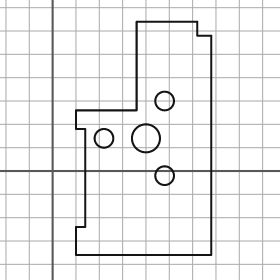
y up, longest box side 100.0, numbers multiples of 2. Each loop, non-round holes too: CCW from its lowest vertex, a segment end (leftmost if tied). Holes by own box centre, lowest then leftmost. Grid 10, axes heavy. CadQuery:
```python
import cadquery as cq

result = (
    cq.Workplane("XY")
    .moveTo(10.0, -36.0)
    .lineTo(68.0, -36.0)
    .lineTo(68.0, 58.0)
    .lineTo(62.0, 58.0)
    .lineTo(62.0, 64.0)
    .lineTo(36.0, 64.0)
    .lineTo(36.0, 26.0)
    .lineTo(10.0, 26.0)
    .lineTo(10.0, 18.0)
    .lineTo(14.0, 18.0)
    .lineTo(14.0, -24.0)
    .lineTo(10.0, -24.0)
    .close()
    .moveTo(48.0, -2.0)
    .circle(4.0)
    .moveTo(22.0, 14.0)
    .circle(4.0)
    .moveTo(40.0, 14.0)
    .circle(6.0)
    .moveTo(48.0, 30.0)
    .circle(4.0)
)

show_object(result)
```